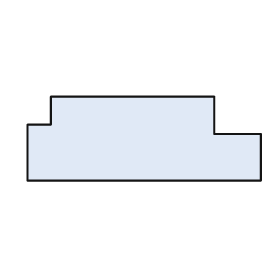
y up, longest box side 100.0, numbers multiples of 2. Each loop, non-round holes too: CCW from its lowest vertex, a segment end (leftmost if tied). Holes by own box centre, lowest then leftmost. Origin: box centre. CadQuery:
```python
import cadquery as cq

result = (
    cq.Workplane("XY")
    .moveTo(-50.0, -18.0)
    .lineTo(50.0, -18.0)
    .lineTo(50.0, 2.0)
    .lineTo(30.0, 2.0)
    .lineTo(30.0, 18.0)
    .lineTo(-40.0, 18.0)
    .lineTo(-40.0, 6.0)
    .lineTo(-50.0, 6.0)
    .close()
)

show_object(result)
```